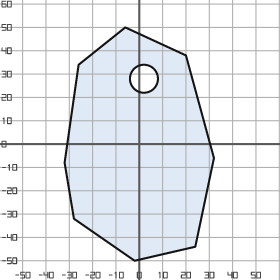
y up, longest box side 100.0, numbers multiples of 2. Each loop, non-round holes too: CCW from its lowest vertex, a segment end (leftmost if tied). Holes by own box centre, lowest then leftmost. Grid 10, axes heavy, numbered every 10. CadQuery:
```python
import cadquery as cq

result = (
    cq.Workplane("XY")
    .moveTo(-2.0, -50.0)
    .lineTo(24.0, -44.0)
    .lineTo(32.0, -6.0)
    .lineTo(20.0, 38.0)
    .lineTo(-6.0, 50.0)
    .lineTo(-26.0, 34.0)
    .lineTo(-32.0, -8.0)
    .lineTo(-28.0, -32.0)
    .close()
    .moveTo(2.0, 28.0)
    .circle(6.0)
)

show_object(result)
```